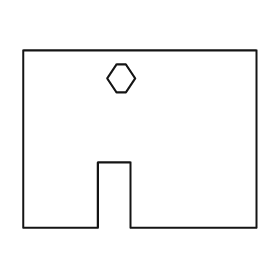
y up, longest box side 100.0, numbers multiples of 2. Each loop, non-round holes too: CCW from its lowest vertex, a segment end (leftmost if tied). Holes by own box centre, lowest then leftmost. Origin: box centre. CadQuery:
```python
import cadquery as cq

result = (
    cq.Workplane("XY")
    .moveTo(-50.0, -38.0)
    .lineTo(-18.0, -38.0)
    .lineTo(-18.0, -10.0)
    .lineTo(-4.0, -10.0)
    .lineTo(-4.0, -38.0)
    .lineTo(50.0, -38.0)
    .lineTo(50.0, 38.0)
    .lineTo(-50.0, 38.0)
    .close()
    .moveTo(-10.0, 20.0)
    .lineTo(-6.0, 20.0)
    .lineTo(-2.0, 26.0)
    .lineTo(-6.0, 32.0)
    .lineTo(-10.0, 32.0)
    .lineTo(-14.0, 26.0)
    .close()
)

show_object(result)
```